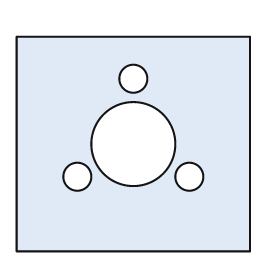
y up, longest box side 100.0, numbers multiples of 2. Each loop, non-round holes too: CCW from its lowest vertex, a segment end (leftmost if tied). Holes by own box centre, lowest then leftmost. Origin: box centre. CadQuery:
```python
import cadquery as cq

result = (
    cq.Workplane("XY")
    .moveTo(-50.0, -46.0)
    .lineTo(50.0, -46.0)
    .lineTo(50.0, 46.0)
    .lineTo(-50.0, 46.0)
    .close()
    .moveTo(-24.0, -14.0)
    .circle(6.0)
    .moveTo(24.0, -14.0)
    .circle(6.0)
    .moveTo(0.0, 0.0)
    .circle(18.0)
    .moveTo(0.0, 28.0)
    .circle(6.0)
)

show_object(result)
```